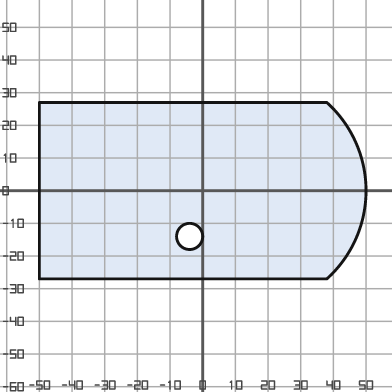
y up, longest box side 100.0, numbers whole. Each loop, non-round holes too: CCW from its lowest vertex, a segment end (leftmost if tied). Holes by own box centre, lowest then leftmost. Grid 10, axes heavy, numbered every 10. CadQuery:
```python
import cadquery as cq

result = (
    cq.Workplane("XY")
    .moveTo(-50.0, -27.0)
    .lineTo(38.0, -27.0)
    .threePointArc((50.0, 0.0), (38.0, 27.0))
    .lineTo(-50.0, 27.0)
    .close()
    .moveTo(-4.0, -14.0)
    .circle(4.0)
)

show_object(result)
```